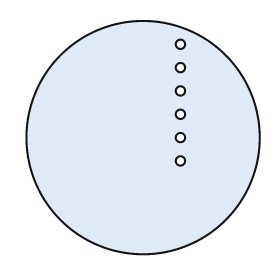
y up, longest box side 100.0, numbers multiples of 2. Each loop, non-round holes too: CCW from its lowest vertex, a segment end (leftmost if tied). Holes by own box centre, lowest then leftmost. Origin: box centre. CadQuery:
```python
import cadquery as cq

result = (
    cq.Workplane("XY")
    .moveTo(0.0, 0.0)
    .circle(50.0)
    .moveTo(16.0, -10.0)
    .circle(2.0)
    .moveTo(16.0, 0.0)
    .circle(2.0)
    .moveTo(16.0, 10.0)
    .circle(2.0)
    .moveTo(16.0, 20.0)
    .circle(2.0)
    .moveTo(16.0, 30.0)
    .circle(2.0)
    .moveTo(16.0, 40.0)
    .circle(2.0)
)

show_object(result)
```